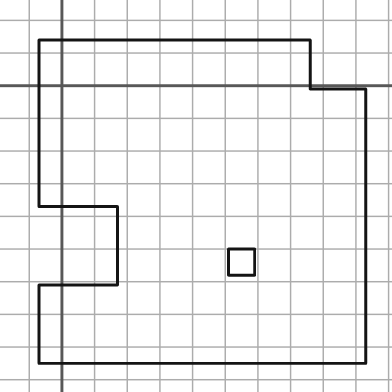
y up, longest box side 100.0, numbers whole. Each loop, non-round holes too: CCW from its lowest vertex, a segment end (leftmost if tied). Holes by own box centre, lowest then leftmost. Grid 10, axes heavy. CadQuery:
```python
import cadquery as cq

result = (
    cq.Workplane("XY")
    .moveTo(-7.0, -85.0)
    .lineTo(93.0, -85.0)
    .lineTo(93.0, -1.0)
    .lineTo(76.0, -1.0)
    .lineTo(76.0, 14.0)
    .lineTo(-7.0, 14.0)
    .lineTo(-7.0, -37.0)
    .lineTo(17.0, -37.0)
    .lineTo(17.0, -61.0)
    .lineTo(-7.0, -61.0)
    .close()
    .moveTo(51.0, -58.0)
    .lineTo(59.0, -58.0)
    .lineTo(59.0, -50.0)
    .lineTo(51.0, -50.0)
    .close()
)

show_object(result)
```